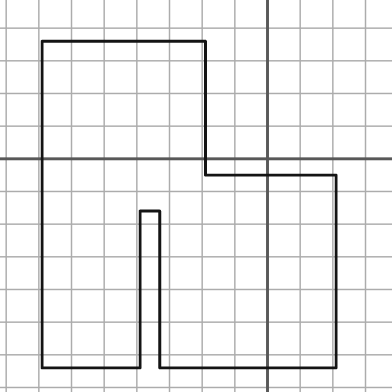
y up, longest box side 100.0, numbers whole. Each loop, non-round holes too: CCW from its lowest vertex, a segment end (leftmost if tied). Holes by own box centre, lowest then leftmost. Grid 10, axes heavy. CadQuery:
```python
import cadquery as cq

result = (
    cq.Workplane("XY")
    .moveTo(-69.0, -64.0)
    .lineTo(-39.0, -64.0)
    .lineTo(-39.0, -16.0)
    .lineTo(-33.0, -16.0)
    .lineTo(-33.0, -64.0)
    .lineTo(21.0, -64.0)
    .lineTo(21.0, -5.0)
    .lineTo(-19.0, -5.0)
    .lineTo(-19.0, 36.0)
    .lineTo(-69.0, 36.0)
    .close()
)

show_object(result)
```